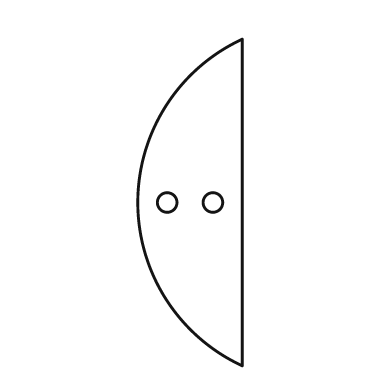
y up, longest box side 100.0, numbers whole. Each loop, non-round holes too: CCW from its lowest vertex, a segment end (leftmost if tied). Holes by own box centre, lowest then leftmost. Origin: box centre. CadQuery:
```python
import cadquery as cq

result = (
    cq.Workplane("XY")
    .moveTo(16.0, -50.0)
    .lineTo(16.0, 50.0)
    .threePointArc((-16.0, 0.0), (16.0, -50.0))
    .close()
    .moveTo(-7.0, 0.0)
    .circle(3.0)
    .moveTo(7.0, 0.0)
    .circle(3.0)
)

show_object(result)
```